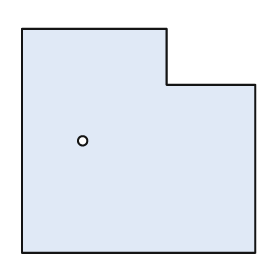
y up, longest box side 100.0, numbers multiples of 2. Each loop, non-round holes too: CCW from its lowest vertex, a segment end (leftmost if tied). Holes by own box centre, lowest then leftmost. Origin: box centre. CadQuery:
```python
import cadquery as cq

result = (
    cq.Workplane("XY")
    .moveTo(-50.0, -48.0)
    .lineTo(50.0, -48.0)
    .lineTo(50.0, 24.0)
    .lineTo(12.0, 24.0)
    .lineTo(12.0, 48.0)
    .lineTo(-50.0, 48.0)
    .close()
    .moveTo(-24.0, 0.0)
    .circle(2.0)
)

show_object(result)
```